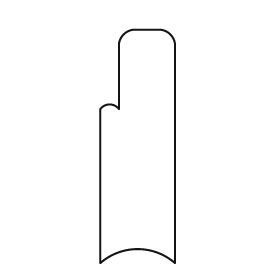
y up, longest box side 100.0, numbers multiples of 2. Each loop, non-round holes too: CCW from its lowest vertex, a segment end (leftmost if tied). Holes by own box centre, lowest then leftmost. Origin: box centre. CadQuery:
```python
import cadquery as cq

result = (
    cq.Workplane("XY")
    .moveTo(-16.0, -50.0)
    .threePointArc((0.0, -44.0), (16.0, -50.0))
    .lineTo(16.0, 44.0)
    .threePointArc((14.0, 48.0), (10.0, 50.0))
    .lineTo(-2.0, 50.0)
    .threePointArc((-6.0, 48.0), (-8.0, 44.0))
    .lineTo(-8.0, 16.0)
    .threePointArc((-12.0, 18.0), (-16.0, 16.0))
    .close()
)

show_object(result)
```